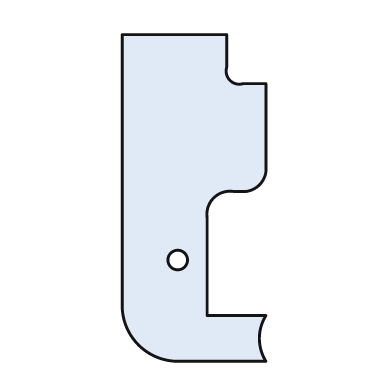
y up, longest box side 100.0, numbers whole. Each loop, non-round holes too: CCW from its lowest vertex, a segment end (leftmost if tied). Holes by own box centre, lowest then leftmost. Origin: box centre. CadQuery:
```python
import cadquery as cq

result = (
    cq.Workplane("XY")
    .moveTo(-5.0, -50.0)
    .lineTo(22.0, -50.0)
    .threePointArc((20.0, -43.0), (22.0, -36.0))
    .lineTo(4.0, -36.0)
    .lineTo(4.0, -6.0)
    .threePointArc((6.0, 0.0), (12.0, 2.0))
    .lineTo(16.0, 2.0)
    .threePointArc((20.0, 4.0), (22.0, 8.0))
    .lineTo(22.0, 35.0)
    .lineTo(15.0, 35.0)
    .threePointArc((11.0, 36.0), (10.0, 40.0))
    .lineTo(10.0, 50.0)
    .lineTo(-22.0, 50.0)
    .lineTo(-22.0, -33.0)
    .threePointArc((-17.0, -45.0), (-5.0, -50.0))
    .close()
    .moveTo(-5.0, -19.0)
    .circle(3.0)
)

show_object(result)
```